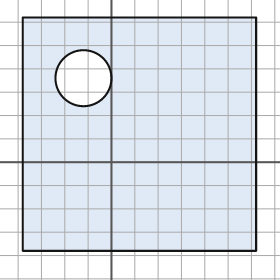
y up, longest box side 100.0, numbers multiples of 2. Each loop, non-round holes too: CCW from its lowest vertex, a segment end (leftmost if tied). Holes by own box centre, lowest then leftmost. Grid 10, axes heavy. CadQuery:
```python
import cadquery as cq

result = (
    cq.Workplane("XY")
    .moveTo(-38.0, -38.0)
    .lineTo(62.0, -38.0)
    .lineTo(62.0, 62.0)
    .lineTo(-38.0, 62.0)
    .close()
    .moveTo(-12.0, 36.0)
    .circle(12.0)
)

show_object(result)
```